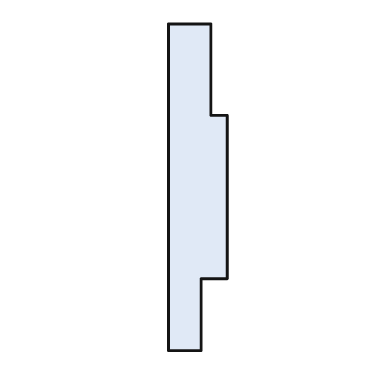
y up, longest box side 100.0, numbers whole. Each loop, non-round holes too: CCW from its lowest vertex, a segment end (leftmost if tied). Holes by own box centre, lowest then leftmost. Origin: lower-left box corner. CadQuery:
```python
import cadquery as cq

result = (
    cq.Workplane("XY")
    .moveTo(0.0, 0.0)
    .lineTo(10.0, 0.0)
    .lineTo(10.0, 22.0)
    .lineTo(18.0, 22.0)
    .lineTo(18.0, 72.0)
    .lineTo(13.0, 72.0)
    .lineTo(13.0, 100.0)
    .lineTo(0.0, 100.0)
    .close()
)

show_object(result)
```